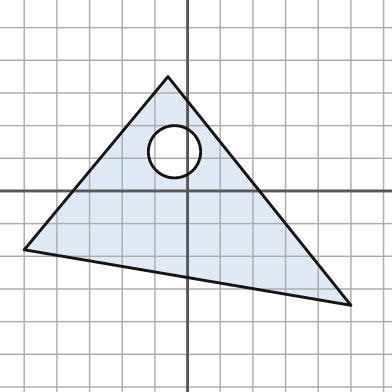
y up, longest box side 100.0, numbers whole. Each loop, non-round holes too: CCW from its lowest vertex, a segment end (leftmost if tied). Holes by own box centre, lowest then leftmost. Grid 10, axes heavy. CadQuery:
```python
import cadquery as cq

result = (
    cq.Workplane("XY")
    .moveTo(50.0, -35.0)
    .lineTo(-6.0, 35.0)
    .lineTo(-50.0, -18.0)
    .close()
    .moveTo(-4.0, 12.0)
    .circle(8.0)
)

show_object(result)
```